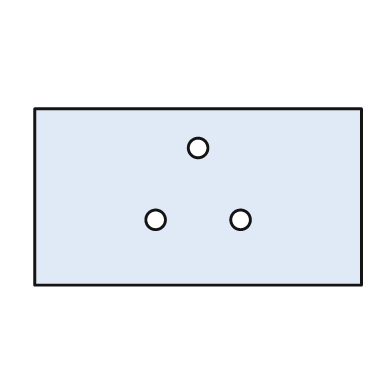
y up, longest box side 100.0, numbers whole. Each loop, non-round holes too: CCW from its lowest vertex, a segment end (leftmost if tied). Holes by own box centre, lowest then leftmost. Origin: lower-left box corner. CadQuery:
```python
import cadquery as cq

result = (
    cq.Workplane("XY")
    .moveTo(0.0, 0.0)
    .lineTo(100.0, 0.0)
    .lineTo(100.0, 54.0)
    .lineTo(0.0, 54.0)
    .close()
    .moveTo(37.0, 20.0)
    .circle(3.0)
    .moveTo(63.0, 20.0)
    .circle(3.0)
    .moveTo(50.0, 42.0)
    .circle(3.0)
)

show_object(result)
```